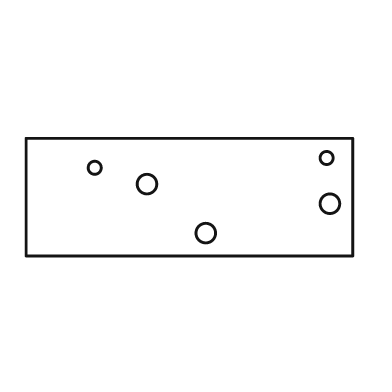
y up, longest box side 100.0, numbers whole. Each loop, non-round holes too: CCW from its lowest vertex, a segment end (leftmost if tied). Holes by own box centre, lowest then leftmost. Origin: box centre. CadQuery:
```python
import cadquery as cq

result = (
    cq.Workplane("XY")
    .moveTo(-50.0, -18.0)
    .lineTo(50.0, -18.0)
    .lineTo(50.0, 18.0)
    .lineTo(-50.0, 18.0)
    .close()
    .moveTo(5.0, -11.0)
    .circle(3.0)
    .moveTo(43.0, -2.0)
    .circle(3.0)
    .moveTo(-13.0, 4.0)
    .circle(3.0)
    .moveTo(-29.0, 9.0)
    .circle(2.0)
    .moveTo(42.0, 12.0)
    .circle(2.0)
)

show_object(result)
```